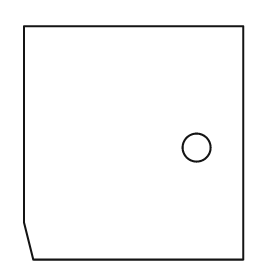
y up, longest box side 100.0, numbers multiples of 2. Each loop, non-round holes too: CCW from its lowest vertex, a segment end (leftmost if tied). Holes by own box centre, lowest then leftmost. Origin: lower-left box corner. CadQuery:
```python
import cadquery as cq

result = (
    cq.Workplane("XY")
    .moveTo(4.0, 0.0)
    .lineTo(94.0, 0.0)
    .lineTo(94.0, 100.0)
    .lineTo(0.0, 100.0)
    .lineTo(0.0, 16.0)
    .close()
    .moveTo(74.0, 48.0)
    .circle(6.0)
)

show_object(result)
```